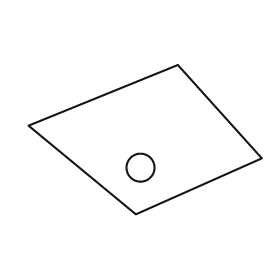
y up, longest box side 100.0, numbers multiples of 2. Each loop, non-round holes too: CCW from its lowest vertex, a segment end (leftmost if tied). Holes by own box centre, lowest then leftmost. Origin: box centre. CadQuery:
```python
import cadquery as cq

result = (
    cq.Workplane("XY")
    .moveTo(-4.0, -32.0)
    .lineTo(50.0, -8.0)
    .lineTo(14.0, 32.0)
    .lineTo(-50.0, 6.0)
    .close()
    .moveTo(-2.0, -12.0)
    .circle(6.0)
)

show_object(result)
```